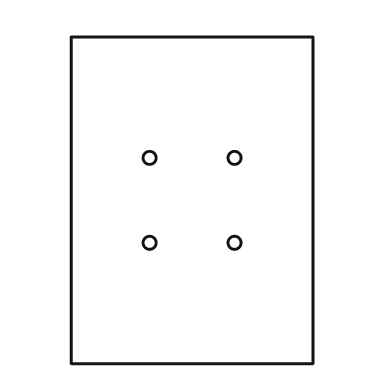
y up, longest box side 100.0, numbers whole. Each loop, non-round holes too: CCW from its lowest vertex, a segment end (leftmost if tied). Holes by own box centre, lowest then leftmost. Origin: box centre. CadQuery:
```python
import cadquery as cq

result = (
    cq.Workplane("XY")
    .moveTo(-37.0, -50.0)
    .lineTo(37.0, -50.0)
    .lineTo(37.0, 50.0)
    .lineTo(-37.0, 50.0)
    .close()
    .moveTo(-13.0, -13.0)
    .circle(2.0)
    .moveTo(13.0, -13.0)
    .circle(2.0)
    .moveTo(-13.0, 13.0)
    .circle(2.0)
    .moveTo(13.0, 13.0)
    .circle(2.0)
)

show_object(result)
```